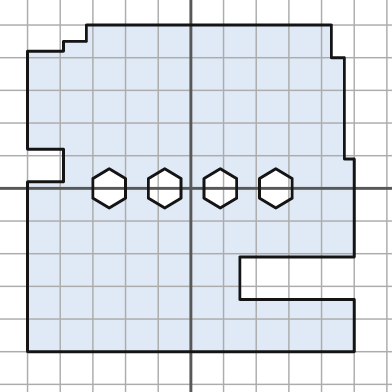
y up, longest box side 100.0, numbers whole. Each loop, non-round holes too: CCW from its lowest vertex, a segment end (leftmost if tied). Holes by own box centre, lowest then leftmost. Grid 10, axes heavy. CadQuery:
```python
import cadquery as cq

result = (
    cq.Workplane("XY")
    .moveTo(-50.0, -50.0)
    .lineTo(50.0, -50.0)
    .lineTo(50.0, -34.0)
    .lineTo(15.0, -34.0)
    .lineTo(15.0, -21.0)
    .lineTo(50.0, -21.0)
    .lineTo(50.0, 9.0)
    .lineTo(47.0, 9.0)
    .lineTo(47.0, 40.0)
    .lineTo(43.0, 40.0)
    .lineTo(43.0, 50.0)
    .lineTo(-32.0, 50.0)
    .lineTo(-32.0, 45.0)
    .lineTo(-39.0, 45.0)
    .lineTo(-39.0, 42.0)
    .lineTo(-50.0, 42.0)
    .lineTo(-50.0, 12.0)
    .lineTo(-39.0, 12.0)
    .lineTo(-39.0, 2.0)
    .lineTo(-50.0, 2.0)
    .close()
    .moveTo(-25.0, -6.0)
    .lineTo(-20.0, -3.0)
    .lineTo(-20.0, 3.0)
    .lineTo(-25.0, 6.0)
    .lineTo(-30.0, 3.0)
    .lineTo(-30.0, -3.0)
    .close()
    .moveTo(-8.0, -6.0)
    .lineTo(-3.0, -3.0)
    .lineTo(-3.0, 3.0)
    .lineTo(-8.0, 6.0)
    .lineTo(-13.0, 3.0)
    .lineTo(-13.0, -3.0)
    .close()
    .moveTo(9.0, -6.0)
    .lineTo(14.0, -3.0)
    .lineTo(14.0, 3.0)
    .lineTo(9.0, 6.0)
    .lineTo(4.0, 3.0)
    .lineTo(4.0, -3.0)
    .close()
    .moveTo(26.0, -6.0)
    .lineTo(31.0, -3.0)
    .lineTo(31.0, 3.0)
    .lineTo(26.0, 6.0)
    .lineTo(21.0, 3.0)
    .lineTo(21.0, -3.0)
    .close()
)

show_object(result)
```